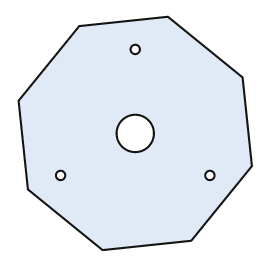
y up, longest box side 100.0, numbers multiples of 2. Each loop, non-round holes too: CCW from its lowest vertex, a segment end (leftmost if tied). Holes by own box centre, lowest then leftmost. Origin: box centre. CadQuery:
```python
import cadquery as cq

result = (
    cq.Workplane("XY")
    .moveTo(-14.0, -50.0)
    .lineTo(24.0, -46.0)
    .lineTo(50.0, -14.0)
    .lineTo(46.0, 24.0)
    .lineTo(14.0, 50.0)
    .lineTo(-24.0, 46.0)
    .lineTo(-50.0, 14.0)
    .lineTo(-46.0, -24.0)
    .close()
    .moveTo(-32.0, -18.0)
    .circle(2.0)
    .moveTo(32.0, -18.0)
    .circle(2.0)
    .moveTo(0.0, 0.0)
    .circle(8.0)
    .moveTo(0.0, 36.0)
    .circle(2.0)
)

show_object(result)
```